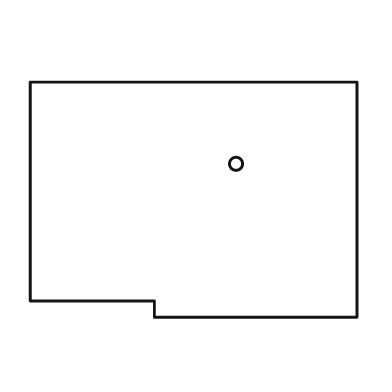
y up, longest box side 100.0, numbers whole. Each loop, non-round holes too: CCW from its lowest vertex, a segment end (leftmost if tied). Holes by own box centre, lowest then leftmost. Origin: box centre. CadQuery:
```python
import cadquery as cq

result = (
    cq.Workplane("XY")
    .moveTo(-12.0, -36.0)
    .lineTo(50.0, -36.0)
    .lineTo(50.0, 36.0)
    .lineTo(-50.0, 36.0)
    .lineTo(-50.0, -31.0)
    .lineTo(-12.0, -31.0)
    .close()
    .moveTo(13.0, 11.0)
    .circle(2.0)
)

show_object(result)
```